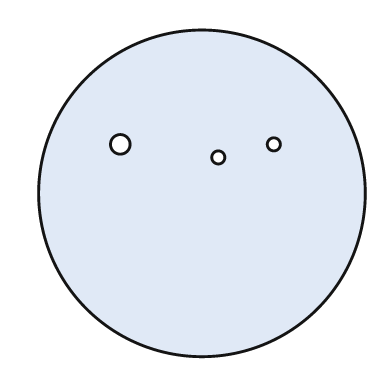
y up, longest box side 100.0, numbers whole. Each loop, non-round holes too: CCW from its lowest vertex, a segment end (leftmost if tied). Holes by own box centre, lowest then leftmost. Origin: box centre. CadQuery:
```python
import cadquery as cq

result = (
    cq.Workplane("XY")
    .moveTo(0.0, 0.0)
    .circle(50.0)
    .moveTo(5.0, 11.0)
    .circle(2.0)
    .moveTo(-25.0, 15.0)
    .circle(3.0)
    .moveTo(22.0, 15.0)
    .circle(2.0)
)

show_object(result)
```